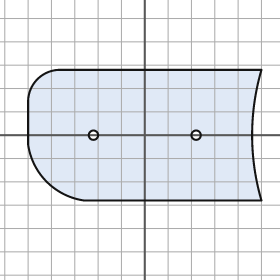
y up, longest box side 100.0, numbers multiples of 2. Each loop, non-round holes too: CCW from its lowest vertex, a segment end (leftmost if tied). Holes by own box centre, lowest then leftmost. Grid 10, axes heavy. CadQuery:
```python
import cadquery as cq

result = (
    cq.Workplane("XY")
    .moveTo(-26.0, -28.0)
    .lineTo(50.0, -28.0)
    .threePointArc((46.0, 0.0), (50.0, 28.0))
    .lineTo(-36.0, 28.0)
    .threePointArc((-46.0, 24.0), (-50.0, 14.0))
    .lineTo(-50.0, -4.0)
    .threePointArc((-42.0, -20.0), (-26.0, -28.0))
    .close()
    .moveTo(-22.0, 0.0)
    .circle(2.0)
    .moveTo(22.0, 0.0)
    .circle(2.0)
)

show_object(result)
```